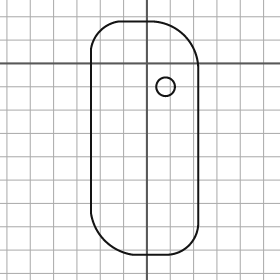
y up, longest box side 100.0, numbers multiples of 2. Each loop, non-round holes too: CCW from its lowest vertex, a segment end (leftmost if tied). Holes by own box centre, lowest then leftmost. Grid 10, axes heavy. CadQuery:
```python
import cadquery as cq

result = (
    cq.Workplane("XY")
    .moveTo(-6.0, -82.0)
    .lineTo(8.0, -82.0)
    .threePointArc((18.0, -78.0), (22.0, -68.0))
    .lineTo(22.0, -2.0)
    .threePointArc((16.0, 12.0), (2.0, 18.0))
    .lineTo(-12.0, 18.0)
    .threePointArc((-20.0, 14.0), (-24.0, 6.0))
    .lineTo(-24.0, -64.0)
    .threePointArc((-18.0, -76.0), (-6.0, -82.0))
    .close()
    .moveTo(8.0, -10.0)
    .circle(4.0)
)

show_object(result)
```